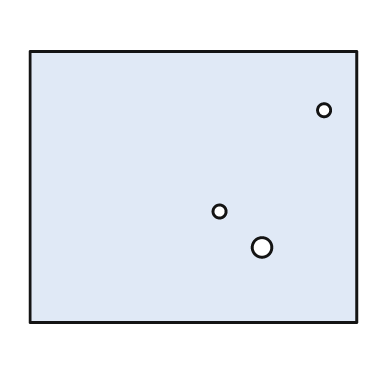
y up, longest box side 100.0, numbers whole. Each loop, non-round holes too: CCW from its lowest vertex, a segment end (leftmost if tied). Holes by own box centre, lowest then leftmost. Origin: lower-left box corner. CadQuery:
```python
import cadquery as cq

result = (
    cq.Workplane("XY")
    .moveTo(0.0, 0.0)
    .lineTo(100.0, 0.0)
    .lineTo(100.0, 83.0)
    .lineTo(0.0, 83.0)
    .close()
    .moveTo(71.0, 23.0)
    .circle(3.0)
    .moveTo(58.0, 34.0)
    .circle(2.0)
    .moveTo(90.0, 65.0)
    .circle(2.0)
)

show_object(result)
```